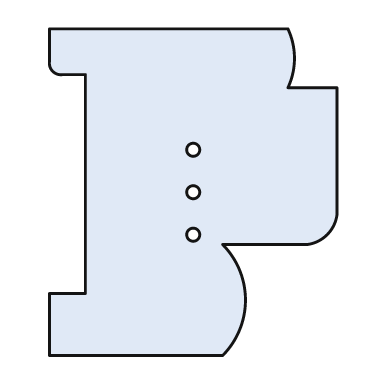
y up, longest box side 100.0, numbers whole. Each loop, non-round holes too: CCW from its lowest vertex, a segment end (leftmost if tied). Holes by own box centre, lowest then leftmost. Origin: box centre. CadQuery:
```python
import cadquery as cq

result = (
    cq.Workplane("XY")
    .moveTo(-44.0, -50.0)
    .lineTo(9.0, -50.0)
    .threePointArc((16.0, -33.0), (9.0, -16.0))
    .lineTo(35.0, -16.0)
    .threePointArc((41.0, -13.0), (44.0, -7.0))
    .lineTo(44.0, 32.0)
    .lineTo(29.0, 32.0)
    .threePointArc((31.0, 41.0), (29.0, 50.0))
    .lineTo(-44.0, 50.0)
    .lineTo(-44.0, 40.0)
    .threePointArc((-43.0, 37.0), (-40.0, 36.0))
    .lineTo(-33.0, 36.0)
    .lineTo(-33.0, -31.0)
    .lineTo(-44.0, -31.0)
    .close()
    .moveTo(0.0, -13.0)
    .circle(2.0)
    .moveTo(0.0, 0.0)
    .circle(2.0)
    .moveTo(0.0, 13.0)
    .circle(2.0)
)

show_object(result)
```